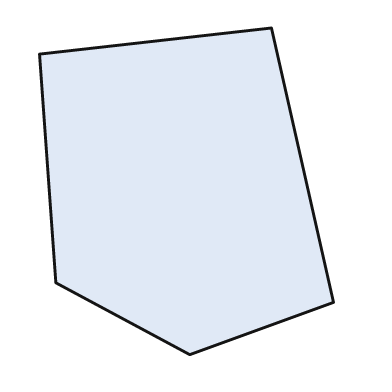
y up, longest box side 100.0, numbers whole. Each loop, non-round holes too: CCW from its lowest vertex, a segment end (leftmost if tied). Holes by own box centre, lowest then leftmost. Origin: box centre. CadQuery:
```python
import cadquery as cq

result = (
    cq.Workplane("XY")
    .moveTo(1.0, -50.0)
    .lineTo(45.0, -34.0)
    .lineTo(26.0, 50.0)
    .lineTo(-45.0, 42.0)
    .lineTo(-40.0, -28.0)
    .close()
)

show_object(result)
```